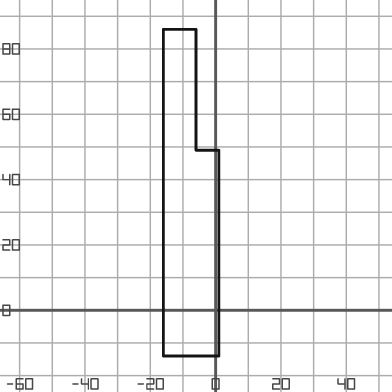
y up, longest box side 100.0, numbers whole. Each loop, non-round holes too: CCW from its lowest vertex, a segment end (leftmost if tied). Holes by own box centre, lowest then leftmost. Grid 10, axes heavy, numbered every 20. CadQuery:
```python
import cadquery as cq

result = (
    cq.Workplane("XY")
    .moveTo(-16.0, -14.0)
    .lineTo(1.0, -14.0)
    .lineTo(1.0, 49.0)
    .lineTo(-6.0, 49.0)
    .lineTo(-6.0, 86.0)
    .lineTo(-16.0, 86.0)
    .close()
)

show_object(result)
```